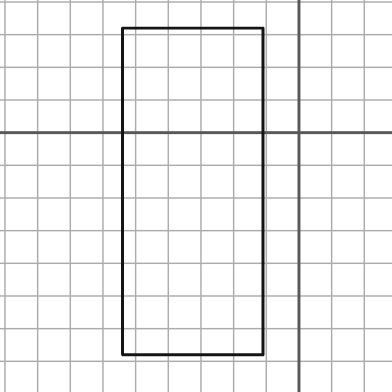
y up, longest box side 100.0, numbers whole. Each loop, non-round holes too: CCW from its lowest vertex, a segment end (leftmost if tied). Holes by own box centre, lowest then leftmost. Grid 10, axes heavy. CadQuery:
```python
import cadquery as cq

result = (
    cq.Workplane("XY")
    .moveTo(-54.0, -68.0)
    .lineTo(-11.0, -68.0)
    .lineTo(-11.0, 32.0)
    .lineTo(-54.0, 32.0)
    .close()
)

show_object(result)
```